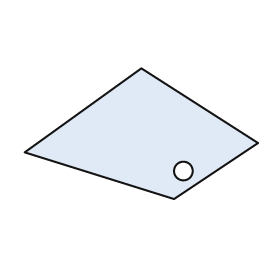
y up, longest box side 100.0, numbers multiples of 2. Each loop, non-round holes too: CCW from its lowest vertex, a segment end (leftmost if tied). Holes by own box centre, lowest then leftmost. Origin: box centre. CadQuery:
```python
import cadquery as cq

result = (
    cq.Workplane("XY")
    .moveTo(14.0, -28.0)
    .lineTo(50.0, -4.0)
    .lineTo(0.0, 28.0)
    .lineTo(-50.0, -8.0)
    .close()
    .moveTo(18.0, -16.0)
    .circle(4.0)
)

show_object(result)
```